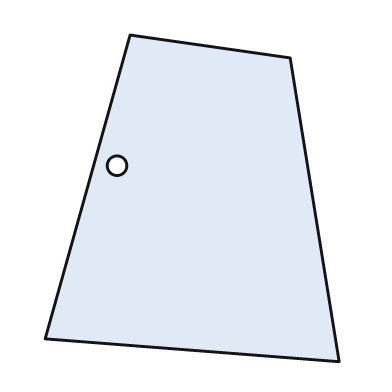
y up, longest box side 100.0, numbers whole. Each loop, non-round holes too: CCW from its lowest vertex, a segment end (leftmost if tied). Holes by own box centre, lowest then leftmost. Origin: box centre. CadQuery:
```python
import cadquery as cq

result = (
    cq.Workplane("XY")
    .moveTo(45.0, -50.0)
    .lineTo(30.0, 43.0)
    .lineTo(-19.0, 50.0)
    .lineTo(-45.0, -43.0)
    .close()
    .moveTo(-23.0, 10.0)
    .circle(3.0)
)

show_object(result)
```